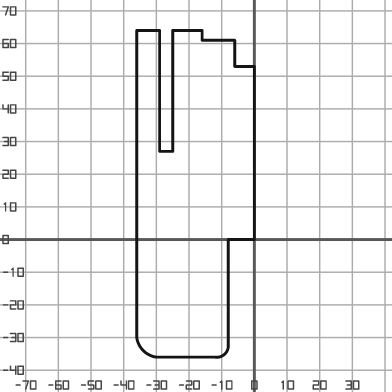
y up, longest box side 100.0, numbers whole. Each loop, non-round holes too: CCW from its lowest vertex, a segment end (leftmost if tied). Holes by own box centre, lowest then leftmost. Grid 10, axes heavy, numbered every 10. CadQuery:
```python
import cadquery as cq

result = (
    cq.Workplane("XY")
    .moveTo(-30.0, -36.0)
    .lineTo(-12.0, -36.0)
    .threePointArc((-9.0, -35.0), (-8.0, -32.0))
    .lineTo(-8.0, 0.0)
    .lineTo(0.0, 0.0)
    .lineTo(0.0, 53.0)
    .lineTo(-6.0, 53.0)
    .lineTo(-6.0, 61.0)
    .lineTo(-16.0, 61.0)
    .lineTo(-16.0, 64.0)
    .lineTo(-25.0, 64.0)
    .lineTo(-25.0, 27.0)
    .lineTo(-29.0, 27.0)
    .lineTo(-29.0, 64.0)
    .lineTo(-36.0, 64.0)
    .lineTo(-36.0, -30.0)
    .threePointArc((-34.0, -34.0), (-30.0, -36.0))
    .close()
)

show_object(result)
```